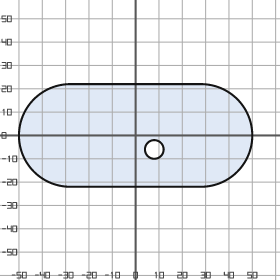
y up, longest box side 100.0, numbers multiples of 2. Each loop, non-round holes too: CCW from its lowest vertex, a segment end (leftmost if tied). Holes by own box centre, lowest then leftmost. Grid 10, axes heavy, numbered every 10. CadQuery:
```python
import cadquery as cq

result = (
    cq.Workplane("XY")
    .moveTo(-28.0, -22.0)
    .lineTo(28.0, -22.0)
    .threePointArc((50.0, 0.0), (28.0, 22.0))
    .lineTo(-28.0, 22.0)
    .threePointArc((-50.0, 0.0), (-28.0, -22.0))
    .close()
    .moveTo(8.0, -6.0)
    .circle(4.0)
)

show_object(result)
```